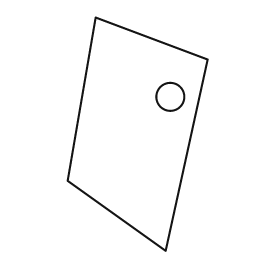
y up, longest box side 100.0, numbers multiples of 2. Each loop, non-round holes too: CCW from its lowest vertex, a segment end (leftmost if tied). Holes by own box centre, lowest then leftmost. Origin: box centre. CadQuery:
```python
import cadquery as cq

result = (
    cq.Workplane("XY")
    .moveTo(12.0, -50.0)
    .lineTo(30.0, 32.0)
    .lineTo(-18.0, 50.0)
    .lineTo(-30.0, -20.0)
    .close()
    .moveTo(14.0, 16.0)
    .circle(6.0)
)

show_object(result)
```